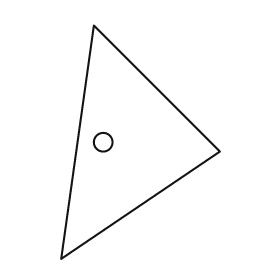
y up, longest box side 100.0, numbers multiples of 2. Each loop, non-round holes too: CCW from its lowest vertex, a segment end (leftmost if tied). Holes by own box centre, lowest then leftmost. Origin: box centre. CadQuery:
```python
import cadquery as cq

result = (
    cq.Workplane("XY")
    .moveTo(-34.0, -50.0)
    .lineTo(34.0, -4.0)
    .lineTo(-20.0, 50.0)
    .close()
    .moveTo(-16.0, 0.0)
    .circle(4.0)
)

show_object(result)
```